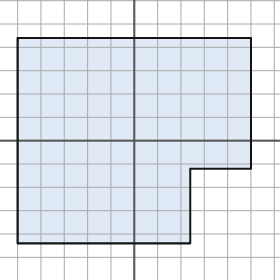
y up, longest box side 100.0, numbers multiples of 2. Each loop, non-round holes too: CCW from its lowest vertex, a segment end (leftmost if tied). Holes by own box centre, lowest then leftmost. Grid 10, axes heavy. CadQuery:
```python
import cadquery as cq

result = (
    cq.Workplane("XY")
    .moveTo(-50.0, -44.0)
    .lineTo(24.0, -44.0)
    .lineTo(24.0, -12.0)
    .lineTo(50.0, -12.0)
    .lineTo(50.0, 44.0)
    .lineTo(-50.0, 44.0)
    .close()
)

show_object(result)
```